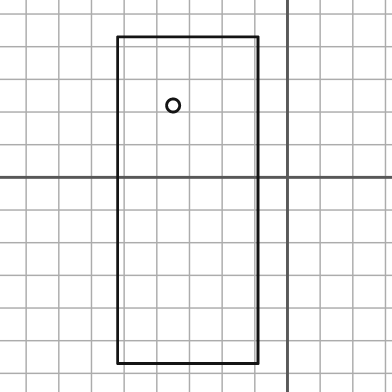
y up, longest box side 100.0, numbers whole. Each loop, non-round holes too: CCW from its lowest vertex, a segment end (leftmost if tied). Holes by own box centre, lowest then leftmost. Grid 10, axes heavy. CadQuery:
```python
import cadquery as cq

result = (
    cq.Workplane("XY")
    .moveTo(-52.0, -57.0)
    .lineTo(-9.0, -57.0)
    .lineTo(-9.0, 43.0)
    .lineTo(-52.0, 43.0)
    .close()
    .moveTo(-35.0, 22.0)
    .circle(2.0)
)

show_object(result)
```